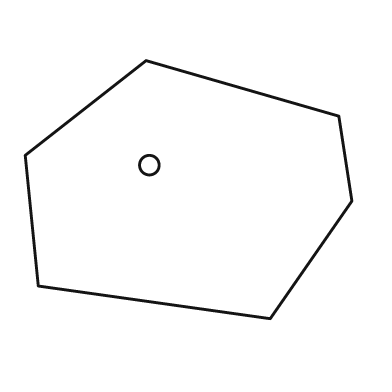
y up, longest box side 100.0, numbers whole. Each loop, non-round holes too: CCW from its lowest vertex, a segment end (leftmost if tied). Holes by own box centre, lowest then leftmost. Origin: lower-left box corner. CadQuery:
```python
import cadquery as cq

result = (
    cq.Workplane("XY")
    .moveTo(75.0, 0.0)
    .lineTo(100.0, 36.0)
    .lineTo(96.0, 62.0)
    .lineTo(37.0, 79.0)
    .lineTo(0.0, 50.0)
    .lineTo(4.0, 10.0)
    .close()
    .moveTo(38.0, 47.0)
    .circle(3.0)
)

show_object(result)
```